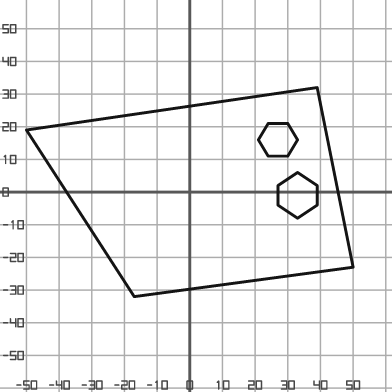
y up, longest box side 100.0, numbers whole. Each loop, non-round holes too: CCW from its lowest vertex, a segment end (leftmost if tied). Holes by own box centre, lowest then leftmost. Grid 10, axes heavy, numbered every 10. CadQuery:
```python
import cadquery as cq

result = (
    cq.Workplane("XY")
    .moveTo(-17.0, -32.0)
    .lineTo(50.0, -23.0)
    .lineTo(39.0, 32.0)
    .lineTo(-50.0, 19.0)
    .close()
    .moveTo(33.0, -8.0)
    .lineTo(39.0, -4.0)
    .lineTo(39.0, 2.0)
    .lineTo(33.0, 6.0)
    .lineTo(27.0, 2.0)
    .lineTo(27.0, -4.0)
    .close()
    .moveTo(24.0, 11.0)
    .lineTo(30.0, 11.0)
    .lineTo(33.0, 16.0)
    .lineTo(30.0, 21.0)
    .lineTo(24.0, 21.0)
    .lineTo(21.0, 16.0)
    .close()
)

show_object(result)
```